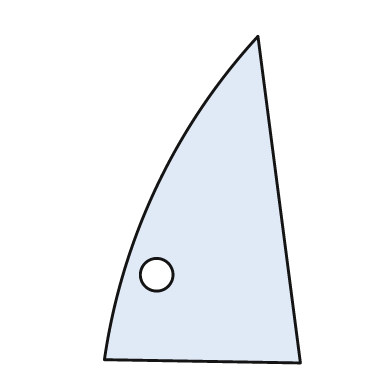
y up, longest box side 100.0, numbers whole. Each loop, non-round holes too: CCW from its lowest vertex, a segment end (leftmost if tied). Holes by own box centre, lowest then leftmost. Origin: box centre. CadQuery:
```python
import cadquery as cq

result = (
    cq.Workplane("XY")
    .moveTo(30.0, -50.0)
    .lineTo(17.0, 50.0)
    .threePointArc((-14.0, 4.0), (-30.0, -49.0))
    .close()
    .moveTo(-14.0, -23.0)
    .circle(5.0)
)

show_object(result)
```